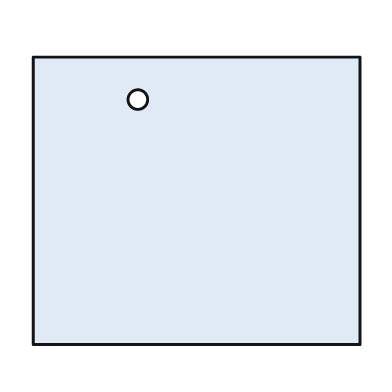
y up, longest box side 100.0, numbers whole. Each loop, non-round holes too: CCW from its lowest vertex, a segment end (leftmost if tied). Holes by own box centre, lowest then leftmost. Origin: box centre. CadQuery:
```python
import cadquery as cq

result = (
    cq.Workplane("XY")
    .moveTo(-50.0, -44.0)
    .lineTo(50.0, -44.0)
    .lineTo(50.0, 44.0)
    .lineTo(-50.0, 44.0)
    .close()
    .moveTo(-18.0, 31.0)
    .circle(3.0)
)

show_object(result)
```